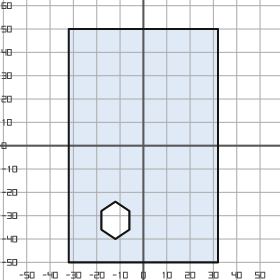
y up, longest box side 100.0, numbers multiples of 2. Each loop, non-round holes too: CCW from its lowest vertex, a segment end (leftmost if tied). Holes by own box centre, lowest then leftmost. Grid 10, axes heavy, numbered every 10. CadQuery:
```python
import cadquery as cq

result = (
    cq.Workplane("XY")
    .moveTo(-32.0, -50.0)
    .lineTo(32.0, -50.0)
    .lineTo(32.0, 50.0)
    .lineTo(-32.0, 50.0)
    .close()
    .moveTo(-12.0, -40.0)
    .lineTo(-6.0, -36.0)
    .lineTo(-6.0, -28.0)
    .lineTo(-12.0, -24.0)
    .lineTo(-18.0, -28.0)
    .lineTo(-18.0, -36.0)
    .close()
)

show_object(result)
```